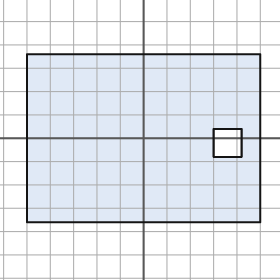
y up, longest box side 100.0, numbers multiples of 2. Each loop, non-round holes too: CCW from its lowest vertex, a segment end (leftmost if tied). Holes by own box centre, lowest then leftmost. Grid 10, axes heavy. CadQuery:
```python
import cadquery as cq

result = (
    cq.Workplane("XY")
    .moveTo(-50.0, -36.0)
    .lineTo(50.0, -36.0)
    .lineTo(50.0, 36.0)
    .lineTo(-50.0, 36.0)
    .close()
    .moveTo(30.0, -8.0)
    .lineTo(42.0, -8.0)
    .lineTo(42.0, 4.0)
    .lineTo(30.0, 4.0)
    .close()
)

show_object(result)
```